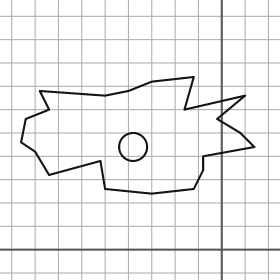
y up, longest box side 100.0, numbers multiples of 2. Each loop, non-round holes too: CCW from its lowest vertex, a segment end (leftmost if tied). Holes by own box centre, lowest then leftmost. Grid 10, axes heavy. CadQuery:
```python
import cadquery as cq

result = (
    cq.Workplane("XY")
    .moveTo(-30.0, 24.0)
    .lineTo(-12.0, 26.0)
    .lineTo(-8.0, 34.0)
    .lineTo(-8.0, 40.0)
    .lineTo(14.0, 44.0)
    .lineTo(8.0, 50.0)
    .lineTo(-2.0, 56.0)
    .lineTo(10.0, 66.0)
    .lineTo(-16.0, 60.0)
    .lineTo(-12.0, 74.0)
    .lineTo(-30.0, 72.0)
    .lineTo(-40.0, 68.0)
    .lineTo(-50.0, 66.0)
    .lineTo(-78.0, 68.0)
    .lineTo(-74.0, 60.0)
    .lineTo(-84.0, 56.0)
    .lineTo(-86.0, 46.0)
    .lineTo(-80.0, 42.0)
    .lineTo(-74.0, 32.0)
    .lineTo(-52.0, 38.0)
    .lineTo(-50.0, 26.0)
    .close()
    .moveTo(-38.0, 44.0)
    .circle(6.0)
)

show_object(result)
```